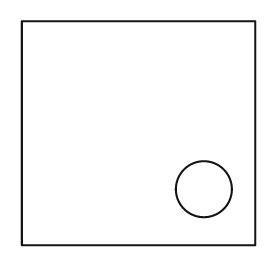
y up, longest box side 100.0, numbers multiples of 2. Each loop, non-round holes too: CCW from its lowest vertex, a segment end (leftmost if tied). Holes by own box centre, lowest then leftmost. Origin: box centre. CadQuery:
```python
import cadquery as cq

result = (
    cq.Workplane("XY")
    .moveTo(-50.0, -48.0)
    .lineTo(50.0, -48.0)
    .lineTo(50.0, 48.0)
    .lineTo(-50.0, 48.0)
    .close()
    .moveTo(28.0, -24.0)
    .circle(12.0)
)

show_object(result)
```